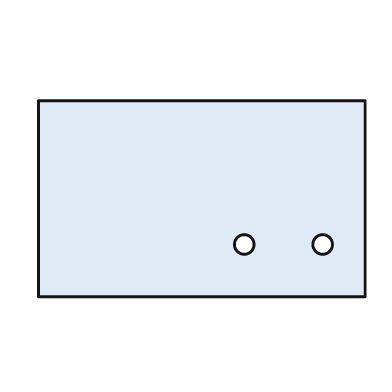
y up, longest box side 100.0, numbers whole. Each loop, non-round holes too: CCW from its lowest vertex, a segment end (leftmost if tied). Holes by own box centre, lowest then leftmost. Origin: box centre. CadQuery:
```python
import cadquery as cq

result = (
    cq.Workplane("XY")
    .moveTo(-50.0, -30.0)
    .lineTo(50.0, -30.0)
    .lineTo(50.0, 30.0)
    .lineTo(-50.0, 30.0)
    .close()
    .moveTo(13.0, -14.0)
    .circle(3.0)
    .moveTo(37.0, -14.0)
    .circle(3.0)
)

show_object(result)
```